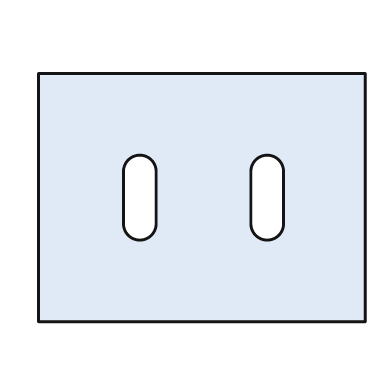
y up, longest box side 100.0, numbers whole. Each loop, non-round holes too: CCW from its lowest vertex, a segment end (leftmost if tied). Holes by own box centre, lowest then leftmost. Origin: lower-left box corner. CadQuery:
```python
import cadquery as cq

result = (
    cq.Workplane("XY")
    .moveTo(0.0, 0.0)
    .lineTo(100.0, 0.0)
    .lineTo(100.0, 76.0)
    .lineTo(0.0, 76.0)
    .close()
    .moveTo(26.0, 30.0)
    .threePointArc((31.0, 25.0), (36.0, 30.0))
    .lineTo(36.0, 46.0)
    .threePointArc((31.0, 51.0), (26.0, 46.0))
    .close()
    .moveTo(65.0, 30.0)
    .threePointArc((70.0, 25.0), (75.0, 30.0))
    .lineTo(75.0, 46.0)
    .threePointArc((70.0, 51.0), (65.0, 46.0))
    .close()
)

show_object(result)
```